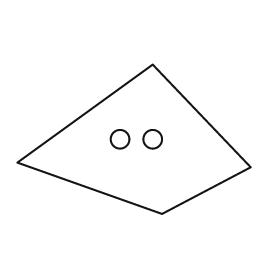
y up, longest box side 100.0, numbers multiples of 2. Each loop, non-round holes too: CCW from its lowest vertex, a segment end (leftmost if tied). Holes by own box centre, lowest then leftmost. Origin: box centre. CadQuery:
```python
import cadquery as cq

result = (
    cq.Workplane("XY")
    .moveTo(12.0, -32.0)
    .lineTo(50.0, -12.0)
    .lineTo(8.0, 32.0)
    .lineTo(-50.0, -10.0)
    .close()
    .moveTo(-6.0, 0.0)
    .circle(4.0)
    .moveTo(8.0, 0.0)
    .circle(4.0)
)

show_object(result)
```